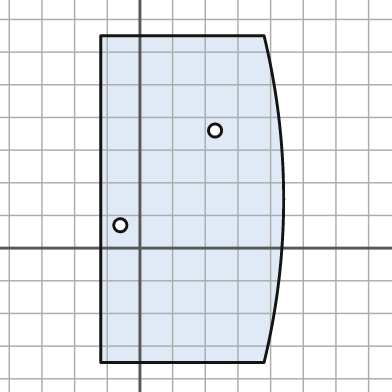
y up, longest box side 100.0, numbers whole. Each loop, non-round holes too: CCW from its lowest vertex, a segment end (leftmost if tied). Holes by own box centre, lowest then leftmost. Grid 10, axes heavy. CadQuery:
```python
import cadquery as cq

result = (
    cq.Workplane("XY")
    .moveTo(-12.0, -35.0)
    .lineTo(38.0, -35.0)
    .threePointArc((44.0, 15.0), (38.0, 65.0))
    .lineTo(-12.0, 65.0)
    .close()
    .moveTo(-6.0, 7.0)
    .circle(2.0)
    .moveTo(23.0, 36.0)
    .circle(2.0)
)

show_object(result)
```